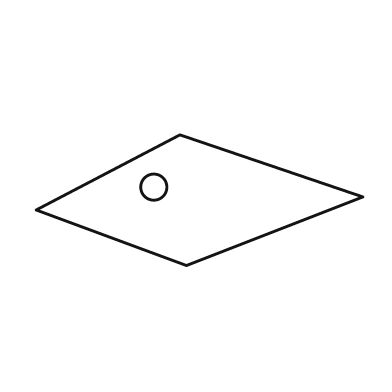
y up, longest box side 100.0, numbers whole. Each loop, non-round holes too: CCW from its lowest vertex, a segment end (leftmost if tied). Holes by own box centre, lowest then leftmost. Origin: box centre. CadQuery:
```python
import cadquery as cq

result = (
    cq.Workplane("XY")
    .moveTo(-4.0, -20.0)
    .lineTo(50.0, 1.0)
    .lineTo(-6.0, 20.0)
    .lineTo(-50.0, -3.0)
    .close()
    .moveTo(-14.0, 4.0)
    .circle(4.0)
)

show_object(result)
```